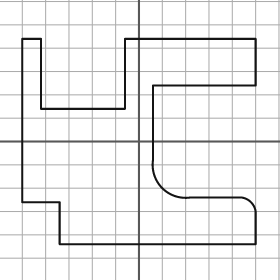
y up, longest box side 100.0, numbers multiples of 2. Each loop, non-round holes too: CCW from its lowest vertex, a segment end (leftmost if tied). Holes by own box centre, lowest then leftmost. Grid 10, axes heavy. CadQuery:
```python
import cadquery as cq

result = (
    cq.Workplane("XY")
    .moveTo(-34.0, -44.0)
    .lineTo(50.0, -44.0)
    .lineTo(50.0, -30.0)
    .threePointArc((48.0, -26.0), (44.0, -24.0))
    .lineTo(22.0, -24.0)
    .threePointArc((10.0, -20.0), (6.0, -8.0))
    .lineTo(6.0, 24.0)
    .lineTo(50.0, 24.0)
    .lineTo(50.0, 44.0)
    .lineTo(-6.0, 44.0)
    .lineTo(-6.0, 14.0)
    .lineTo(-42.0, 14.0)
    .lineTo(-42.0, 44.0)
    .lineTo(-50.0, 44.0)
    .lineTo(-50.0, -26.0)
    .lineTo(-34.0, -26.0)
    .close()
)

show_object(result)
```